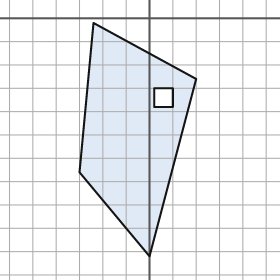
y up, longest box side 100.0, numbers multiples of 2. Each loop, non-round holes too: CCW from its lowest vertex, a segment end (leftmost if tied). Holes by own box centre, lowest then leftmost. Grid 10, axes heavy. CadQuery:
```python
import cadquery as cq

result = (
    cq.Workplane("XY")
    .moveTo(0.0, -102.0)
    .lineTo(20.0, -26.0)
    .lineTo(-24.0, -2.0)
    .lineTo(-30.0, -66.0)
    .close()
    .moveTo(2.0, -38.0)
    .lineTo(10.0, -38.0)
    .lineTo(10.0, -30.0)
    .lineTo(2.0, -30.0)
    .close()
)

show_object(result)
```